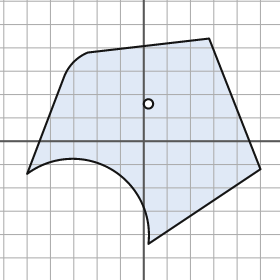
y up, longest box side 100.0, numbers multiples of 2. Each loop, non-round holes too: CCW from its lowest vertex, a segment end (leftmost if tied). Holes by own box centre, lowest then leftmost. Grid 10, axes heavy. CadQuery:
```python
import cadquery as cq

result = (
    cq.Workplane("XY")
    .moveTo(2.0, -44.0)
    .lineTo(50.0, -12.0)
    .lineTo(28.0, 44.0)
    .lineTo(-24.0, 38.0)
    .threePointArc((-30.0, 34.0), (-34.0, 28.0))
    .lineTo(-50.0, -14.0)
    .threePointArc((-14.0, -12.0), (2.0, -44.0))
    .close()
    .moveTo(2.0, 16.0)
    .circle(2.0)
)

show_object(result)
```